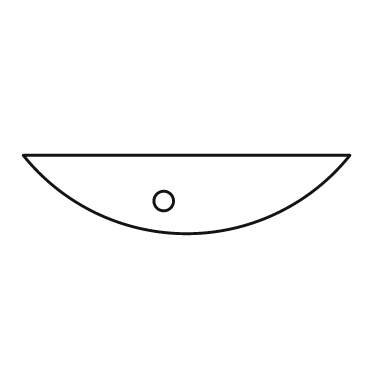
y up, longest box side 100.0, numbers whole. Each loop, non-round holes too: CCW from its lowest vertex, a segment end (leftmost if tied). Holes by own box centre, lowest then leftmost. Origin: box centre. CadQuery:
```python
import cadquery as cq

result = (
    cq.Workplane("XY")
    .moveTo(-50.0, 12.0)
    .threePointArc((0.0, -12.0), (50.0, 12.0))
    .close()
    .moveTo(-7.0, -2.0)
    .circle(3.0)
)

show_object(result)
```